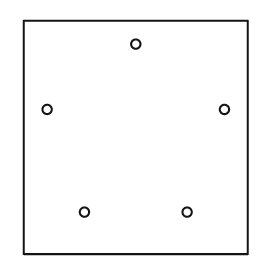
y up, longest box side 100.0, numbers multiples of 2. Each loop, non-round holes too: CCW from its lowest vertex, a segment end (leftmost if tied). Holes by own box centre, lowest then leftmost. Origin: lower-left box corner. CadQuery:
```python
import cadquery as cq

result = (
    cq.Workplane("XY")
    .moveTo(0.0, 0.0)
    .lineTo(96.0, 0.0)
    .lineTo(96.0, 100.0)
    .lineTo(0.0, 100.0)
    .close()
    .moveTo(26.0, 18.0)
    .circle(2.0)
    .moveTo(70.0, 18.0)
    .circle(2.0)
    .moveTo(10.0, 62.0)
    .circle(2.0)
    .moveTo(86.0, 62.0)
    .circle(2.0)
    .moveTo(48.0, 90.0)
    .circle(2.0)
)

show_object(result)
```